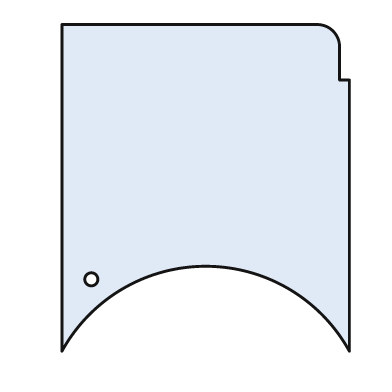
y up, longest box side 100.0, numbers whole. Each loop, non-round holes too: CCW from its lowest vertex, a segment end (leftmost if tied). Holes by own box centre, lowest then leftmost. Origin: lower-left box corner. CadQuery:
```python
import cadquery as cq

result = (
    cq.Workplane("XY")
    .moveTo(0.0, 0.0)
    .threePointArc((44.0, 26.0), (88.0, 0.0))
    .lineTo(88.0, 83.0)
    .lineTo(85.0, 83.0)
    .lineTo(85.0, 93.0)
    .threePointArc((83.0, 98.0), (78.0, 100.0))
    .lineTo(0.0, 100.0)
    .close()
    .moveTo(9.0, 22.0)
    .circle(2.0)
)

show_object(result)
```